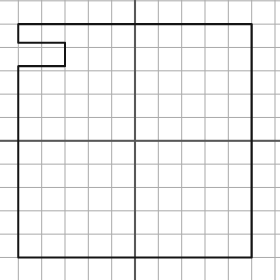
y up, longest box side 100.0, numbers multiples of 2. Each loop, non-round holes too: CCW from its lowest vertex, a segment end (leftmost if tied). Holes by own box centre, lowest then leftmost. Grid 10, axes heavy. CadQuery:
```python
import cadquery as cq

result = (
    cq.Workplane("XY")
    .moveTo(-50.0, -50.0)
    .lineTo(50.0, -50.0)
    .lineTo(50.0, 50.0)
    .lineTo(-50.0, 50.0)
    .lineTo(-50.0, 42.0)
    .lineTo(-30.0, 42.0)
    .lineTo(-30.0, 32.0)
    .lineTo(-50.0, 32.0)
    .close()
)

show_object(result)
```